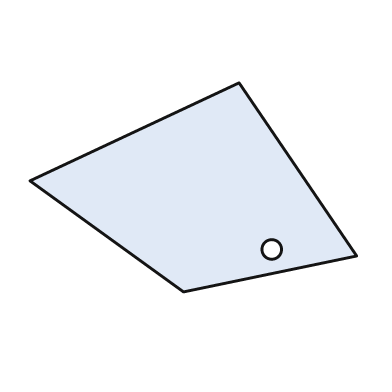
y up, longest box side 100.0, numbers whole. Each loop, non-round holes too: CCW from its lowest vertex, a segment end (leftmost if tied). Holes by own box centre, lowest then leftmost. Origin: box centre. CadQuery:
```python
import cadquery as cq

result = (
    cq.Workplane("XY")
    .moveTo(-3.0, -32.0)
    .lineTo(50.0, -21.0)
    .lineTo(14.0, 32.0)
    .lineTo(-50.0, 2.0)
    .close()
    .moveTo(24.0, -19.0)
    .circle(3.0)
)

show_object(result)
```